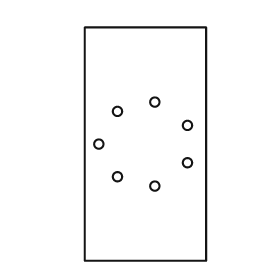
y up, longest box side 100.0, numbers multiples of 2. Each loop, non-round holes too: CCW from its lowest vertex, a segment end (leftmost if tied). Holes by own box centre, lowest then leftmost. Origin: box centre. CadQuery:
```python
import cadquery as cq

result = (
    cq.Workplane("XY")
    .moveTo(-26.0, -50.0)
    .lineTo(26.0, -50.0)
    .lineTo(26.0, 50.0)
    .lineTo(-26.0, 50.0)
    .close()
    .moveTo(4.0, -18.0)
    .circle(2.0)
    .moveTo(-12.0, -14.0)
    .circle(2.0)
    .moveTo(18.0, -8.0)
    .circle(2.0)
    .moveTo(-20.0, 0.0)
    .circle(2.0)
    .moveTo(18.0, 8.0)
    .circle(2.0)
    .moveTo(-12.0, 14.0)
    .circle(2.0)
    .moveTo(4.0, 18.0)
    .circle(2.0)
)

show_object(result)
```